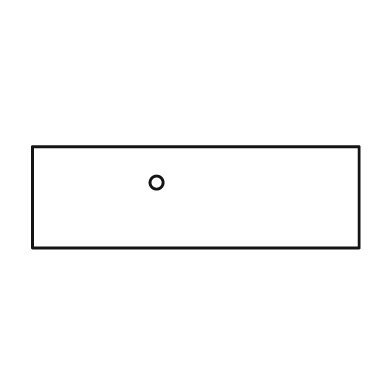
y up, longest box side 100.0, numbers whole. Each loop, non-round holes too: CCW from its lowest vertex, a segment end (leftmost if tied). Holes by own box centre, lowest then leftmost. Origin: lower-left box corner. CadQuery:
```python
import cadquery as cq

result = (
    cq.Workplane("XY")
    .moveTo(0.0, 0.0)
    .lineTo(100.0, 0.0)
    .lineTo(100.0, 31.0)
    .lineTo(0.0, 31.0)
    .close()
    .moveTo(38.0, 20.0)
    .circle(2.0)
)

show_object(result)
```